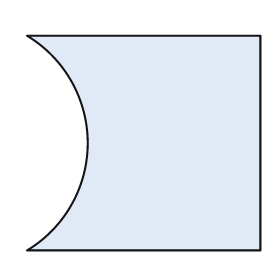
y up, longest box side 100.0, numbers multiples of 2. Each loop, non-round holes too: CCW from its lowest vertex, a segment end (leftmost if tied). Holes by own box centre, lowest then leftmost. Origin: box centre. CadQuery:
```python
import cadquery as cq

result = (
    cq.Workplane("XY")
    .moveTo(-50.0, -46.0)
    .lineTo(50.0, -46.0)
    .lineTo(50.0, 46.0)
    .lineTo(-50.0, 46.0)
    .threePointArc((-24.0, 0.0), (-50.0, -46.0))
    .close()
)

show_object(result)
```